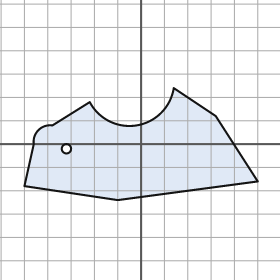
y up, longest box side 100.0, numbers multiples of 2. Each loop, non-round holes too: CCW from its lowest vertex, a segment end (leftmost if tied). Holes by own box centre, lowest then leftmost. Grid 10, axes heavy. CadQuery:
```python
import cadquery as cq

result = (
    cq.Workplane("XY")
    .moveTo(-10.0, -24.0)
    .lineTo(50.0, -16.0)
    .lineTo(32.0, 12.0)
    .lineTo(14.0, 24.0)
    .threePointArc((-2.0, 8.0), (-22.0, 18.0))
    .lineTo(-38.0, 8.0)
    .threePointArc((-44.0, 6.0), (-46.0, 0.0))
    .lineTo(-50.0, -18.0)
    .close()
    .moveTo(-32.0, -2.0)
    .circle(2.0)
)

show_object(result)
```